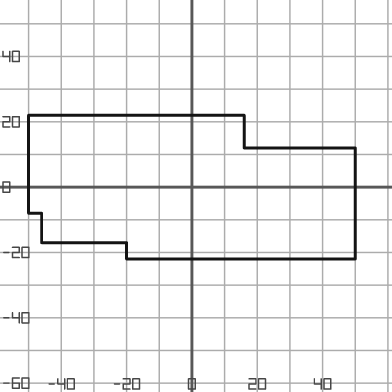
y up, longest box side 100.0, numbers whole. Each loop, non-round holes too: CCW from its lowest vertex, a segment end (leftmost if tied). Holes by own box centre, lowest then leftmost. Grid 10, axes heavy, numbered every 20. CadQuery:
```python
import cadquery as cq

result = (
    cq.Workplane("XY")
    .moveTo(-20.0, -22.0)
    .lineTo(50.0, -22.0)
    .lineTo(50.0, 12.0)
    .lineTo(16.0, 12.0)
    .lineTo(16.0, 22.0)
    .lineTo(-50.0, 22.0)
    .lineTo(-50.0, -8.0)
    .lineTo(-46.0, -8.0)
    .lineTo(-46.0, -17.0)
    .lineTo(-20.0, -17.0)
    .close()
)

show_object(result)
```